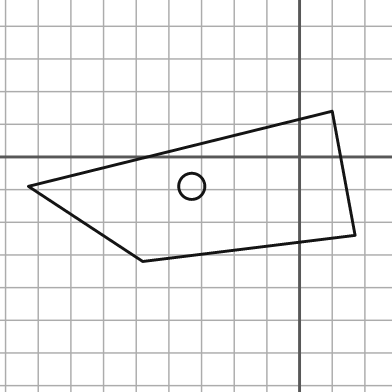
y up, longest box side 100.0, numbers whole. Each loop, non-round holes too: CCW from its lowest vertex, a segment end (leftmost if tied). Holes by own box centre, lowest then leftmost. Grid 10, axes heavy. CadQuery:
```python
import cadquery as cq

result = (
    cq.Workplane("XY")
    .moveTo(-48.0, -32.0)
    .lineTo(17.0, -24.0)
    .lineTo(10.0, 14.0)
    .lineTo(-83.0, -9.0)
    .close()
    .moveTo(-33.0, -9.0)
    .circle(4.0)
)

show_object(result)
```